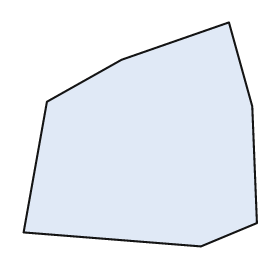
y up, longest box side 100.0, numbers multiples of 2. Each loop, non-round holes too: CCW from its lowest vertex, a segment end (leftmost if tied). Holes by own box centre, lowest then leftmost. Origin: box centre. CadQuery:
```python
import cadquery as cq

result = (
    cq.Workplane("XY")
    .moveTo(26.0, -48.0)
    .lineTo(50.0, -38.0)
    .lineTo(48.0, 12.0)
    .lineTo(38.0, 48.0)
    .lineTo(-8.0, 32.0)
    .lineTo(-40.0, 14.0)
    .lineTo(-50.0, -42.0)
    .close()
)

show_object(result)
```